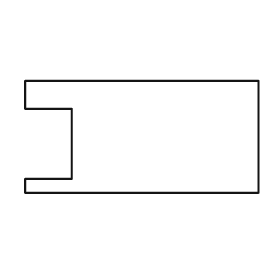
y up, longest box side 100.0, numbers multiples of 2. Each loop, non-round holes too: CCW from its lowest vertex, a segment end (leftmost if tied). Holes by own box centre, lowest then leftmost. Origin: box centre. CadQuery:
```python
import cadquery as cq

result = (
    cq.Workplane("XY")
    .moveTo(-50.0, -24.0)
    .lineTo(50.0, -24.0)
    .lineTo(50.0, 24.0)
    .lineTo(-50.0, 24.0)
    .lineTo(-50.0, 12.0)
    .lineTo(-30.0, 12.0)
    .lineTo(-30.0, -18.0)
    .lineTo(-50.0, -18.0)
    .close()
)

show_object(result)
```